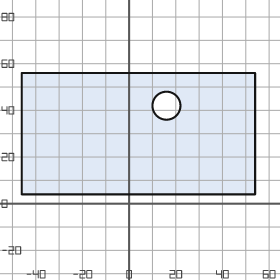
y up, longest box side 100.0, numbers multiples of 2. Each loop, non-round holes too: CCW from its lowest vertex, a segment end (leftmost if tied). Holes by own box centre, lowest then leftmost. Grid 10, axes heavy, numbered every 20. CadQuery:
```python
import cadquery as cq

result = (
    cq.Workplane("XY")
    .moveTo(-46.0, 4.0)
    .lineTo(54.0, 4.0)
    .lineTo(54.0, 56.0)
    .lineTo(-46.0, 56.0)
    .close()
    .moveTo(16.0, 42.0)
    .circle(6.0)
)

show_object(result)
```